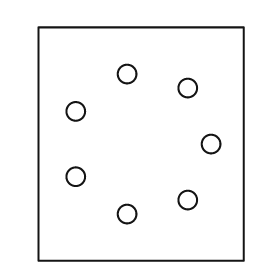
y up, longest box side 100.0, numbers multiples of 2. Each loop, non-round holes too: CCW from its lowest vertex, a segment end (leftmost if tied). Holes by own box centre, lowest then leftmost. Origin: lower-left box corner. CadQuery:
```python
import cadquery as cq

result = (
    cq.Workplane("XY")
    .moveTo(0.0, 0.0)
    .lineTo(88.0, 0.0)
    .lineTo(88.0, 100.0)
    .lineTo(0.0, 100.0)
    .close()
    .moveTo(38.0, 20.0)
    .circle(4.0)
    .moveTo(64.0, 26.0)
    .circle(4.0)
    .moveTo(16.0, 36.0)
    .circle(4.0)
    .moveTo(74.0, 50.0)
    .circle(4.0)
    .moveTo(16.0, 64.0)
    .circle(4.0)
    .moveTo(64.0, 74.0)
    .circle(4.0)
    .moveTo(38.0, 80.0)
    .circle(4.0)
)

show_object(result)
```